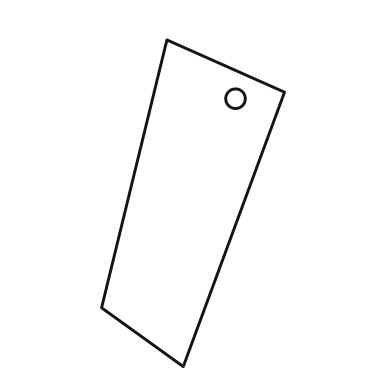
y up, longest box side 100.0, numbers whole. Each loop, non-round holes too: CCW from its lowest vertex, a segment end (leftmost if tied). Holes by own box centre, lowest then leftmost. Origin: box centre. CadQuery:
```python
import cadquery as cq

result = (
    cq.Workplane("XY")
    .moveTo(-3.0, -50.0)
    .lineTo(28.0, 34.0)
    .lineTo(-8.0, 50.0)
    .lineTo(-28.0, -32.0)
    .close()
    .moveTo(13.0, 32.0)
    .circle(3.0)
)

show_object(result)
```